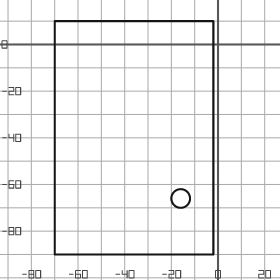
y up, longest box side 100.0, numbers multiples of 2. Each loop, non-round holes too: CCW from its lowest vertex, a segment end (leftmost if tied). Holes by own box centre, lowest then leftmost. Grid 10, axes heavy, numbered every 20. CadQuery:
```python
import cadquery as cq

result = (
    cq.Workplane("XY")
    .moveTo(-70.0, -90.0)
    .lineTo(-2.0, -90.0)
    .lineTo(-2.0, 10.0)
    .lineTo(-70.0, 10.0)
    .close()
    .moveTo(-16.0, -66.0)
    .circle(4.0)
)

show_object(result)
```